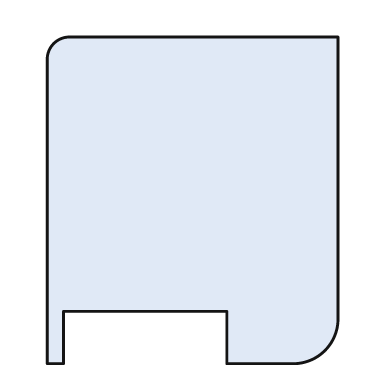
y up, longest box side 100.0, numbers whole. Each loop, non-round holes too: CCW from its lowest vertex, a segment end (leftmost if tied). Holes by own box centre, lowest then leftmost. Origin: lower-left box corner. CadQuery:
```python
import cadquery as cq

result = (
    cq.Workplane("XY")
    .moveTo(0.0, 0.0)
    .lineTo(5.0, 0.0)
    .lineTo(5.0, 16.0)
    .lineTo(55.0, 16.0)
    .lineTo(55.0, 0.0)
    .lineTo(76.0, 0.0)
    .threePointArc((85.0, 4.0), (89.0, 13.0))
    .lineTo(89.0, 100.0)
    .lineTo(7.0, 100.0)
    .threePointArc((2.0, 98.0), (0.0, 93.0))
    .close()
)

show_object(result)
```